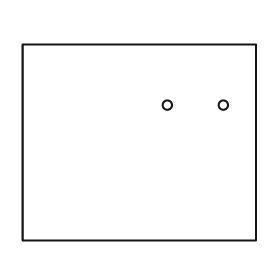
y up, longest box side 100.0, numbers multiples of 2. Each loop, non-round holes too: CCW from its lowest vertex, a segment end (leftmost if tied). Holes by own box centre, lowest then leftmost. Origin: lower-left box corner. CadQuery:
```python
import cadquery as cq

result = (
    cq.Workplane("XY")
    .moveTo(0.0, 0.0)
    .lineTo(100.0, 0.0)
    .lineTo(100.0, 84.0)
    .lineTo(0.0, 84.0)
    .close()
    .moveTo(62.0, 58.0)
    .circle(2.0)
    .moveTo(86.0, 58.0)
    .circle(2.0)
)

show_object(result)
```